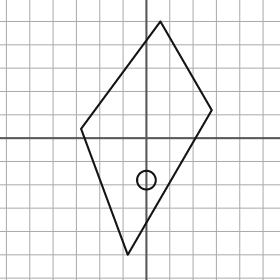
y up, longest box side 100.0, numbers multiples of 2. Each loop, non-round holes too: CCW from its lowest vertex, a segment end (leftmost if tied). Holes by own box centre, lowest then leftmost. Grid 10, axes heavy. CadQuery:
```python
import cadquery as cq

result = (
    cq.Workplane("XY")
    .moveTo(-8.0, -50.0)
    .lineTo(28.0, 12.0)
    .lineTo(6.0, 50.0)
    .lineTo(-28.0, 4.0)
    .close()
    .moveTo(0.0, -18.0)
    .circle(4.0)
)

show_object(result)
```